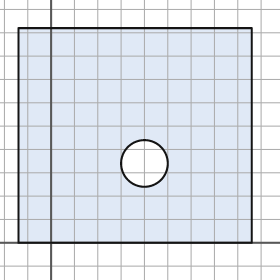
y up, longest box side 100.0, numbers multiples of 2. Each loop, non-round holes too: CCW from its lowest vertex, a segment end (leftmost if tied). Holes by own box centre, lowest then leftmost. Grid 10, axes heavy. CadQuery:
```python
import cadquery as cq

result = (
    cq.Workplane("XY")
    .moveTo(-14.0, 0.0)
    .lineTo(86.0, 0.0)
    .lineTo(86.0, 92.0)
    .lineTo(-14.0, 92.0)
    .close()
    .moveTo(40.0, 34.0)
    .circle(10.0)
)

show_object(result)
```